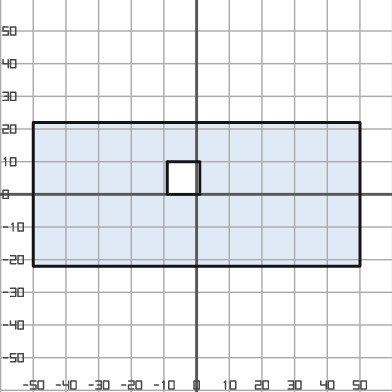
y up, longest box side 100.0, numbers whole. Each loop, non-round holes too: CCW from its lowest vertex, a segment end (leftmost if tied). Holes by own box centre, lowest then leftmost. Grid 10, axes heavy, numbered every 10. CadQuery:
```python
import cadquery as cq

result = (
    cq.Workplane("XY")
    .moveTo(-50.0, -22.0)
    .lineTo(50.0, -22.0)
    .lineTo(50.0, 22.0)
    .lineTo(-50.0, 22.0)
    .close()
    .moveTo(-9.0, 0.0)
    .lineTo(1.0, 0.0)
    .lineTo(1.0, 10.0)
    .lineTo(-9.0, 10.0)
    .close()
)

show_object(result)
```